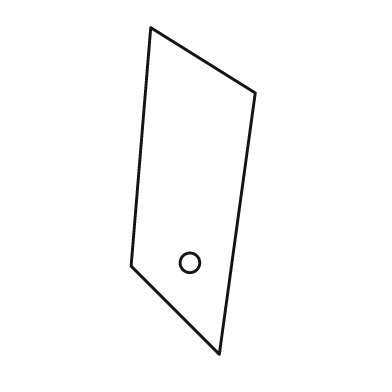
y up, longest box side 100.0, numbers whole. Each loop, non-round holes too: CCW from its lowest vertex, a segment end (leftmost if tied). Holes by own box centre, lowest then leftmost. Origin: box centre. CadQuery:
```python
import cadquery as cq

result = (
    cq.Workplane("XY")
    .moveTo(8.0, -50.0)
    .lineTo(19.0, 30.0)
    .lineTo(-13.0, 50.0)
    .lineTo(-19.0, -23.0)
    .close()
    .moveTo(-1.0, -22.0)
    .circle(3.0)
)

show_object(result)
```